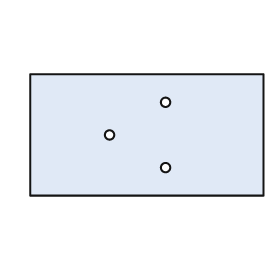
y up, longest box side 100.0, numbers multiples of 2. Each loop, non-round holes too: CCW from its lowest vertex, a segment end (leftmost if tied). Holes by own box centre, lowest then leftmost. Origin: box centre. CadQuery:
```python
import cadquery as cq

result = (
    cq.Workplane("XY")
    .moveTo(-50.0, -26.0)
    .lineTo(50.0, -26.0)
    .lineTo(50.0, 26.0)
    .lineTo(-50.0, 26.0)
    .close()
    .moveTo(8.0, -14.0)
    .circle(2.0)
    .moveTo(-16.0, 0.0)
    .circle(2.0)
    .moveTo(8.0, 14.0)
    .circle(2.0)
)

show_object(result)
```